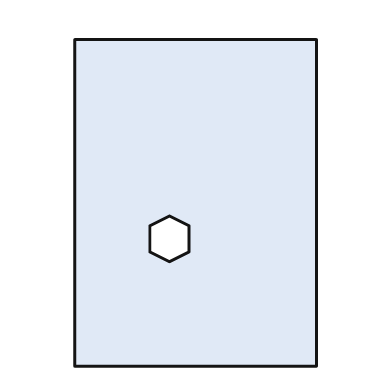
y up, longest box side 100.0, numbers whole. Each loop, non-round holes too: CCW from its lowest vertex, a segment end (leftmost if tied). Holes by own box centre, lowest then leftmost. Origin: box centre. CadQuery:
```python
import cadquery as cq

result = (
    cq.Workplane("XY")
    .moveTo(-37.0, -50.0)
    .lineTo(37.0, -50.0)
    .lineTo(37.0, 50.0)
    .lineTo(-37.0, 50.0)
    .close()
    .moveTo(-8.0, -18.0)
    .lineTo(-2.0, -15.0)
    .lineTo(-2.0, -7.0)
    .lineTo(-8.0, -4.0)
    .lineTo(-14.0, -7.0)
    .lineTo(-14.0, -15.0)
    .close()
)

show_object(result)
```